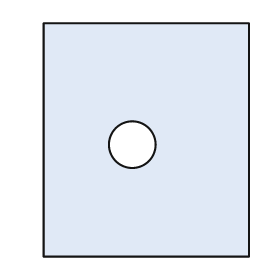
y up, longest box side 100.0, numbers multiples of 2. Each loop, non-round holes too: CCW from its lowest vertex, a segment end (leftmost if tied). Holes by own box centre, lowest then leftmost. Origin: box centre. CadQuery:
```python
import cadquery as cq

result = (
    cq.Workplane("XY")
    .moveTo(-44.0, -50.0)
    .lineTo(44.0, -50.0)
    .lineTo(44.0, 50.0)
    .lineTo(-44.0, 50.0)
    .close()
    .moveTo(-6.0, -2.0)
    .circle(10.0)
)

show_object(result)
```